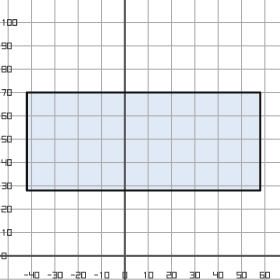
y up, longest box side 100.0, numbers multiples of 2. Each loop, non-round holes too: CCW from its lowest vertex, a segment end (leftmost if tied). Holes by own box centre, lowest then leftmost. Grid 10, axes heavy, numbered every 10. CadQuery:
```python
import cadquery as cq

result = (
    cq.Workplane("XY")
    .moveTo(-42.0, 28.0)
    .lineTo(58.0, 28.0)
    .lineTo(58.0, 70.0)
    .lineTo(-42.0, 70.0)
    .close()
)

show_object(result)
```